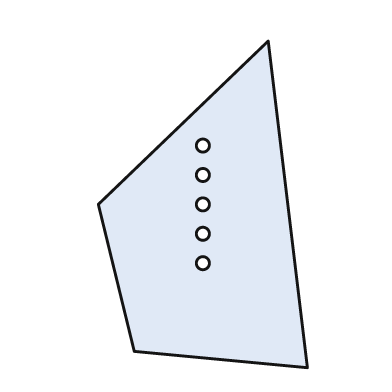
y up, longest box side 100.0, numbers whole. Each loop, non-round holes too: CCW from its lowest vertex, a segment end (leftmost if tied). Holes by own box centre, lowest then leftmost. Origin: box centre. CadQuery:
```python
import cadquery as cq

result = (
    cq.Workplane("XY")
    .moveTo(32.0, -50.0)
    .lineTo(20.0, 50.0)
    .lineTo(-32.0, 0.0)
    .lineTo(-21.0, -45.0)
    .close()
    .moveTo(0.0, -18.0)
    .circle(2.0)
    .moveTo(0.0, -9.0)
    .circle(2.0)
    .moveTo(0.0, 0.0)
    .circle(2.0)
    .moveTo(0.0, 9.0)
    .circle(2.0)
    .moveTo(0.0, 18.0)
    .circle(2.0)
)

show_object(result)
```